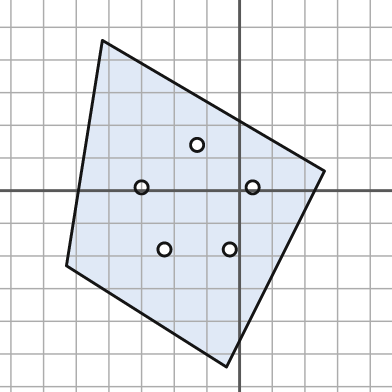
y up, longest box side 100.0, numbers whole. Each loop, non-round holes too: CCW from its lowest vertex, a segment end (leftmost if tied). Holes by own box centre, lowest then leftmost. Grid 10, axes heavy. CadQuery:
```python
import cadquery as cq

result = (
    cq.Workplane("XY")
    .moveTo(-4.0, -54.0)
    .lineTo(26.0, 6.0)
    .lineTo(-42.0, 46.0)
    .lineTo(-53.0, -23.0)
    .close()
    .moveTo(-23.0, -18.0)
    .circle(2.0)
    .moveTo(-3.0, -18.0)
    .circle(2.0)
    .moveTo(-30.0, 1.0)
    .circle(2.0)
    .moveTo(4.0, 1.0)
    .circle(2.0)
    .moveTo(-13.0, 14.0)
    .circle(2.0)
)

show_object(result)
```